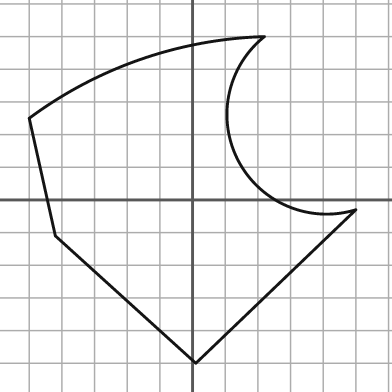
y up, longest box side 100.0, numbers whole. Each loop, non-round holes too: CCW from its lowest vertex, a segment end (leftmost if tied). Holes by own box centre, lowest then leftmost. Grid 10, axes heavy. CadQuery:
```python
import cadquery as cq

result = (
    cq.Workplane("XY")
    .moveTo(1.0, -50.0)
    .lineTo(50.0, -3.0)
    .threePointArc((14.0, 12.0), (22.0, 50.0))
    .threePointArc((-16.0, 43.0), (-50.0, 25.0))
    .lineTo(-42.0, -11.0)
    .close()
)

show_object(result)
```